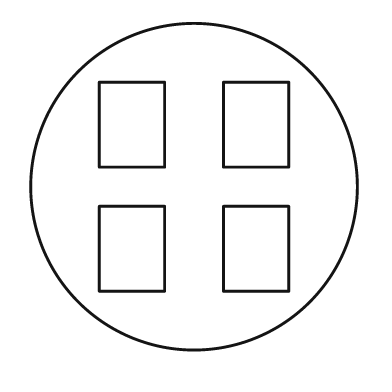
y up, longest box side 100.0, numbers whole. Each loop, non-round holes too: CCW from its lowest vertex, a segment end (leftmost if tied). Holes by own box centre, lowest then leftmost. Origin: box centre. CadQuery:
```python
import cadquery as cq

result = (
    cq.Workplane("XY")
    .moveTo(0.0, 0.0)
    .circle(50.0)
    .moveTo(-29.0, -32.0)
    .lineTo(-9.0, -32.0)
    .lineTo(-9.0, -6.0)
    .lineTo(-29.0, -6.0)
    .close()
    .moveTo(9.0, -32.0)
    .lineTo(29.0, -32.0)
    .lineTo(29.0, -6.0)
    .lineTo(9.0, -6.0)
    .close()
    .moveTo(-29.0, 6.0)
    .lineTo(-9.0, 6.0)
    .lineTo(-9.0, 32.0)
    .lineTo(-29.0, 32.0)
    .close()
    .moveTo(9.0, 6.0)
    .lineTo(29.0, 6.0)
    .lineTo(29.0, 32.0)
    .lineTo(9.0, 32.0)
    .close()
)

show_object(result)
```